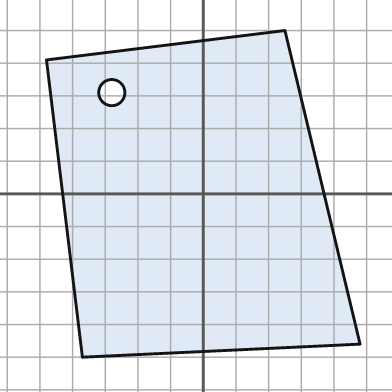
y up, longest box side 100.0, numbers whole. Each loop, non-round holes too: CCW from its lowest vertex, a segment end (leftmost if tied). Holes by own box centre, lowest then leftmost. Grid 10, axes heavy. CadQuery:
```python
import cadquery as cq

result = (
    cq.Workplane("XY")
    .moveTo(-37.0, -50.0)
    .lineTo(48.0, -46.0)
    .lineTo(25.0, 50.0)
    .lineTo(-48.0, 41.0)
    .close()
    .moveTo(-28.0, 31.0)
    .circle(4.0)
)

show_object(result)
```